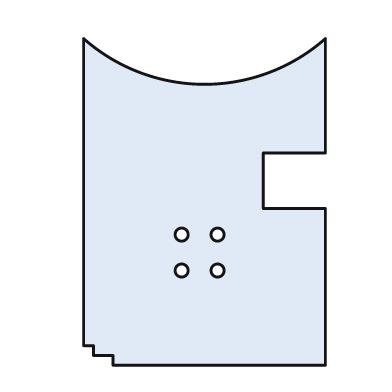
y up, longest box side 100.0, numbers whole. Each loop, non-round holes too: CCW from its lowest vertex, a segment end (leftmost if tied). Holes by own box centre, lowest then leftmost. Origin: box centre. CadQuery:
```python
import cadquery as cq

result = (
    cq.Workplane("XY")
    .moveTo(-28.0, -50.0)
    .lineTo(37.0, -50.0)
    .lineTo(37.0, -2.0)
    .lineTo(18.0, -2.0)
    .lineTo(18.0, 15.0)
    .lineTo(37.0, 15.0)
    .lineTo(37.0, 50.0)
    .threePointArc((0.0, 36.0), (-37.0, 50.0))
    .lineTo(-37.0, -44.0)
    .lineTo(-34.0, -44.0)
    .lineTo(-34.0, -47.0)
    .lineTo(-28.0, -47.0)
    .close()
    .moveTo(-7.0, -21.0)
    .circle(2.0)
    .moveTo(4.0, -21.0)
    .circle(2.0)
    .moveTo(-7.0, -10.0)
    .circle(2.0)
    .moveTo(4.0, -10.0)
    .circle(2.0)
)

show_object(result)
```